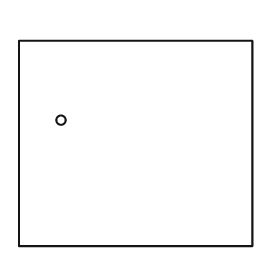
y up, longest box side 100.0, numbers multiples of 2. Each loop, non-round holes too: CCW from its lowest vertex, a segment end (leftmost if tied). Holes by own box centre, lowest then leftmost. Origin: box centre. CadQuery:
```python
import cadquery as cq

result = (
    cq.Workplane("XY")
    .moveTo(-50.0, -44.0)
    .lineTo(50.0, -44.0)
    .lineTo(50.0, 44.0)
    .lineTo(-50.0, 44.0)
    .close()
    .moveTo(-32.0, 10.0)
    .circle(2.0)
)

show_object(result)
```